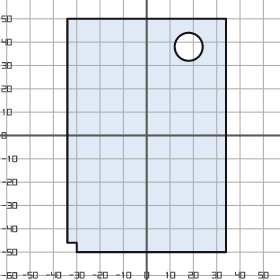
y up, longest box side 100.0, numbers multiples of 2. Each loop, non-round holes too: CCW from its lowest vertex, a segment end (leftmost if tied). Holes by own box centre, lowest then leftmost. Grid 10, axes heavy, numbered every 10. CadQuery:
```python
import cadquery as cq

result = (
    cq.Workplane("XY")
    .moveTo(-30.0, -50.0)
    .lineTo(34.0, -50.0)
    .lineTo(34.0, 50.0)
    .lineTo(-34.0, 50.0)
    .lineTo(-34.0, -46.0)
    .lineTo(-30.0, -46.0)
    .close()
    .moveTo(18.0, 38.0)
    .circle(6.0)
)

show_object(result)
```